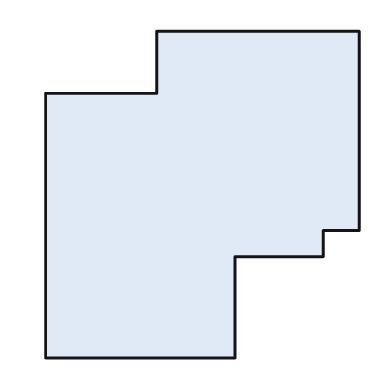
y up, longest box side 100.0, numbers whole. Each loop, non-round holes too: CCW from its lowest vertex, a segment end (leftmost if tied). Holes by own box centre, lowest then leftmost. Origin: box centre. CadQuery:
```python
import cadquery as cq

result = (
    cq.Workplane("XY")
    .moveTo(-48.0, -50.0)
    .lineTo(10.0, -50.0)
    .lineTo(10.0, -19.0)
    .lineTo(37.0, -19.0)
    .lineTo(37.0, -11.0)
    .lineTo(48.0, -11.0)
    .lineTo(48.0, 50.0)
    .lineTo(-14.0, 50.0)
    .lineTo(-14.0, 31.0)
    .lineTo(-48.0, 31.0)
    .close()
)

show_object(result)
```